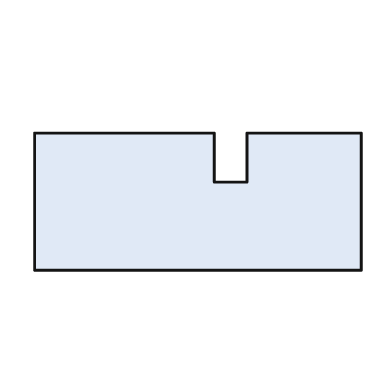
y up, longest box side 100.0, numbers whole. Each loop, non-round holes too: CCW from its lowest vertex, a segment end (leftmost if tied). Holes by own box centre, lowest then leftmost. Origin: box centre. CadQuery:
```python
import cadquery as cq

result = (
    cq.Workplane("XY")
    .moveTo(-50.0, -21.0)
    .lineTo(50.0, -21.0)
    .lineTo(50.0, 21.0)
    .lineTo(15.0, 21.0)
    .lineTo(15.0, 6.0)
    .lineTo(5.0, 6.0)
    .lineTo(5.0, 21.0)
    .lineTo(-50.0, 21.0)
    .close()
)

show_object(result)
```